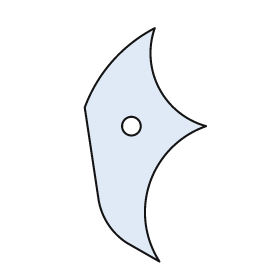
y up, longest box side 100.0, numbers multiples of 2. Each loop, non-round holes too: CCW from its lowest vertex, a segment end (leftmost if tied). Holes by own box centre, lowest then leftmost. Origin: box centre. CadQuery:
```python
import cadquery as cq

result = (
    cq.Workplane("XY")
    .moveTo(6.0, -50.0)
    .threePointArc((2.0, -16.0), (26.0, 8.0))
    .threePointArc((6.0, 24.0), (4.0, 50.0))
    .threePointArc((-14.0, 36.0), (-26.0, 16.0))
    .lineTo(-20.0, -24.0)
    .threePointArc((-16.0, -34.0), (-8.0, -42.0))
    .close()
    .moveTo(-6.0, 8.0)
    .circle(4.0)
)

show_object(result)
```